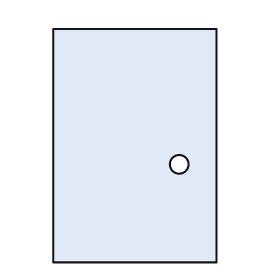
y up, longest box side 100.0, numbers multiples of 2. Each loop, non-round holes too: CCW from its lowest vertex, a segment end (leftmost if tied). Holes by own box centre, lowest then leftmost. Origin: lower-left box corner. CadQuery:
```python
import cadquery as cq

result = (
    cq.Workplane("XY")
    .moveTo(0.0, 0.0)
    .lineTo(70.0, 0.0)
    .lineTo(70.0, 100.0)
    .lineTo(0.0, 100.0)
    .close()
    .moveTo(54.0, 42.0)
    .circle(4.0)
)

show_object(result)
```